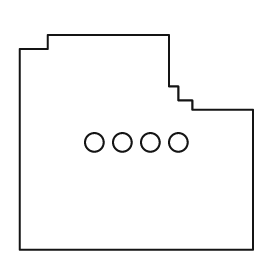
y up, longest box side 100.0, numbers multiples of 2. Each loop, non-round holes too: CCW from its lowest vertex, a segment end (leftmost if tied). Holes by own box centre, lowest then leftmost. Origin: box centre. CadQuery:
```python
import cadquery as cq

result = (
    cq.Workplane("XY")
    .moveTo(-50.0, -46.0)
    .lineTo(50.0, -46.0)
    .lineTo(50.0, 14.0)
    .lineTo(24.0, 14.0)
    .lineTo(24.0, 18.0)
    .lineTo(18.0, 18.0)
    .lineTo(18.0, 24.0)
    .lineTo(14.0, 24.0)
    .lineTo(14.0, 46.0)
    .lineTo(-38.0, 46.0)
    .lineTo(-38.0, 40.0)
    .lineTo(-50.0, 40.0)
    .close()
    .moveTo(-18.0, 0.0)
    .circle(4.0)
    .moveTo(-6.0, 0.0)
    .circle(4.0)
    .moveTo(6.0, 0.0)
    .circle(4.0)
    .moveTo(18.0, 0.0)
    .circle(4.0)
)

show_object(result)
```